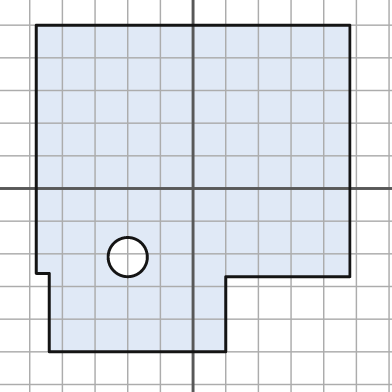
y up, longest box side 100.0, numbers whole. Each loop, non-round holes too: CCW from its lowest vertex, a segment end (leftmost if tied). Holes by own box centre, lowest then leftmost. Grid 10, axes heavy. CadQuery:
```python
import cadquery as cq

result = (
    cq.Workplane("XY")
    .moveTo(-44.0, -50.0)
    .lineTo(10.0, -50.0)
    .lineTo(10.0, -27.0)
    .lineTo(48.0, -27.0)
    .lineTo(48.0, 50.0)
    .lineTo(-48.0, 50.0)
    .lineTo(-48.0, -26.0)
    .lineTo(-44.0, -26.0)
    .close()
    .moveTo(-20.0, -21.0)
    .circle(6.0)
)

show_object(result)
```